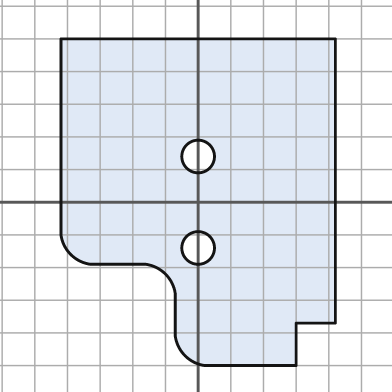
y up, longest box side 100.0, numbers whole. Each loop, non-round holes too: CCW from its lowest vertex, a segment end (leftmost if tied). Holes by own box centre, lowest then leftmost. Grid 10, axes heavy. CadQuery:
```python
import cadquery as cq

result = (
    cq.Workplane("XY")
    .moveTo(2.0, -50.0)
    .lineTo(30.0, -50.0)
    .lineTo(30.0, -37.0)
    .lineTo(42.0, -37.0)
    .lineTo(42.0, 50.0)
    .lineTo(-42.0, 50.0)
    .lineTo(-42.0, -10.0)
    .threePointArc((-39.0, -16.0), (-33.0, -19.0))
    .lineTo(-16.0, -19.0)
    .threePointArc((-10.0, -22.0), (-7.0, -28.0))
    .lineTo(-7.0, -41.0)
    .threePointArc((-4.0, -47.0), (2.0, -50.0))
    .close()
    .moveTo(0.0, -14.0)
    .circle(5.0)
    .moveTo(0.0, 14.0)
    .circle(5.0)
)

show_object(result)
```